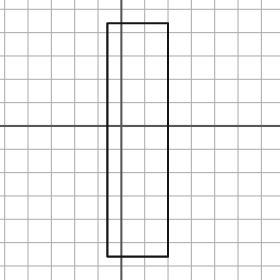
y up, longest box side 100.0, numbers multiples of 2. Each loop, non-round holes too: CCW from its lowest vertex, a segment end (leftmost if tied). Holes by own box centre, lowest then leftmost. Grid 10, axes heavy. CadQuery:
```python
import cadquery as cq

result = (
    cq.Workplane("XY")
    .moveTo(-6.0, -56.0)
    .lineTo(20.0, -56.0)
    .lineTo(20.0, 44.0)
    .lineTo(-6.0, 44.0)
    .close()
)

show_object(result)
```